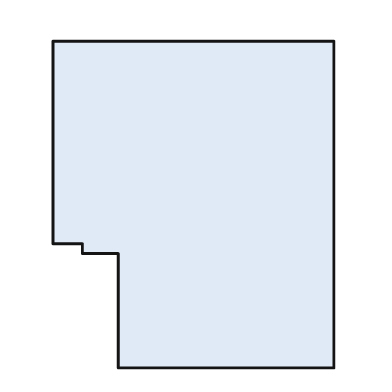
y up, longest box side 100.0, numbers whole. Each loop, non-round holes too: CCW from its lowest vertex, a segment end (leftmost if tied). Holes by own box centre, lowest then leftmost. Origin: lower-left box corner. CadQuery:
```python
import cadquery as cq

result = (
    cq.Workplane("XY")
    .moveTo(20.0, 0.0)
    .lineTo(86.0, 0.0)
    .lineTo(86.0, 100.0)
    .lineTo(0.0, 100.0)
    .lineTo(0.0, 38.0)
    .lineTo(9.0, 38.0)
    .lineTo(9.0, 35.0)
    .lineTo(20.0, 35.0)
    .close()
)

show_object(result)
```